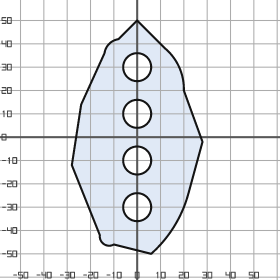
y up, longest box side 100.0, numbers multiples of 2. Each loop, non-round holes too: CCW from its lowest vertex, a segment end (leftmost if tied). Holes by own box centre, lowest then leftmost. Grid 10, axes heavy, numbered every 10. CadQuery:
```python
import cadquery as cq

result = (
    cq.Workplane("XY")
    .moveTo(6.0, -50.0)
    .threePointArc((16.0, -38.0), (22.0, -24.0))
    .lineTo(28.0, -2.0)
    .lineTo(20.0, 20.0)
    .threePointArc((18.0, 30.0), (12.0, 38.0))
    .lineTo(0.0, 50.0)
    .lineTo(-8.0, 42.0)
    .threePointArc((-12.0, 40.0), (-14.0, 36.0))
    .lineTo(-24.0, 14.0)
    .lineTo(-28.0, -12.0)
    .lineTo(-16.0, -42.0)
    .threePointArc((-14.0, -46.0), (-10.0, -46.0))
    .close()
    .moveTo(0.0, -30.0)
    .circle(6.0)
    .moveTo(0.0, -10.0)
    .circle(6.0)
    .moveTo(0.0, 10.0)
    .circle(6.0)
    .moveTo(0.0, 30.0)
    .circle(6.0)
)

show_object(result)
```